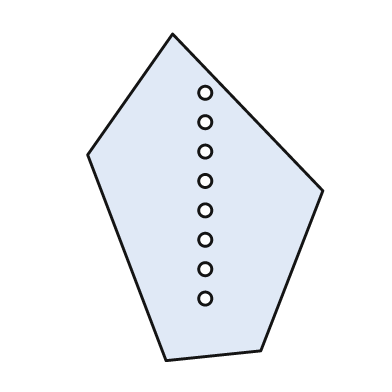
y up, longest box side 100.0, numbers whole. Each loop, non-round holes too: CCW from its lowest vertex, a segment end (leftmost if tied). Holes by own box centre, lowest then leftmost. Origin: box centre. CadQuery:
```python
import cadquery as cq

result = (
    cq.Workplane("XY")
    .moveTo(-12.0, -50.0)
    .lineTo(17.0, -47.0)
    .lineTo(36.0, 2.0)
    .lineTo(-10.0, 50.0)
    .lineTo(-36.0, 13.0)
    .close()
    .moveTo(0.0, -31.0)
    .circle(2.0)
    .moveTo(0.0, -22.0)
    .circle(2.0)
    .moveTo(0.0, -13.0)
    .circle(2.0)
    .moveTo(0.0, -4.0)
    .circle(2.0)
    .moveTo(0.0, 5.0)
    .circle(2.0)
    .moveTo(0.0, 14.0)
    .circle(2.0)
    .moveTo(0.0, 23.0)
    .circle(2.0)
    .moveTo(0.0, 32.0)
    .circle(2.0)
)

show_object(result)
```